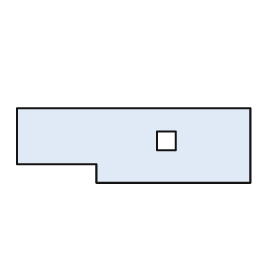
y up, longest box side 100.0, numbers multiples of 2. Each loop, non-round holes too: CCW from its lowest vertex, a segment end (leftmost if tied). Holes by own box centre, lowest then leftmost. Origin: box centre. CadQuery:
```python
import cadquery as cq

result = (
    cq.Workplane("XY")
    .moveTo(-16.0, -16.0)
    .lineTo(50.0, -16.0)
    .lineTo(50.0, 16.0)
    .lineTo(-50.0, 16.0)
    .lineTo(-50.0, -8.0)
    .lineTo(-16.0, -8.0)
    .close()
    .moveTo(10.0, -2.0)
    .lineTo(18.0, -2.0)
    .lineTo(18.0, 6.0)
    .lineTo(10.0, 6.0)
    .close()
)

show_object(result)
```